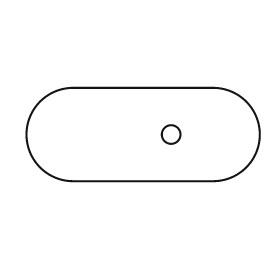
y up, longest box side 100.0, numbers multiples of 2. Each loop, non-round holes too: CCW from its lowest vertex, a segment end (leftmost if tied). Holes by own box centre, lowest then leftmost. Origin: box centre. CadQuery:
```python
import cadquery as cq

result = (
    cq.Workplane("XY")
    .moveTo(-30.0, -20.0)
    .lineTo(30.0, -20.0)
    .threePointArc((50.0, 0.0), (30.0, 20.0))
    .lineTo(-30.0, 20.0)
    .threePointArc((-50.0, 0.0), (-30.0, -20.0))
    .close()
    .moveTo(12.0, 0.0)
    .circle(4.0)
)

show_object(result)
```